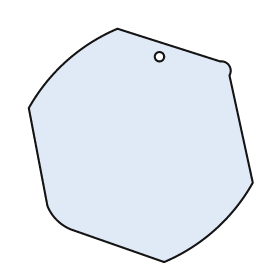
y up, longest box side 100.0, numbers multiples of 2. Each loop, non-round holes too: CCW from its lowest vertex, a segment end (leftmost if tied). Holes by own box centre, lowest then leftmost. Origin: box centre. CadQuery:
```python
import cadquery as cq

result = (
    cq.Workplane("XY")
    .moveTo(10.0, -50.0)
    .threePointArc((32.0, -36.0), (48.0, -16.0))
    .lineTo(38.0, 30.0)
    .threePointArc((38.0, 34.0), (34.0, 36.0))
    .lineTo(-10.0, 50.0)
    .threePointArc((-32.0, 36.0), (-48.0, 16.0))
    .lineTo(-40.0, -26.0)
    .threePointArc((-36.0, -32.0), (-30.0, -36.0))
    .close()
    .moveTo(8.0, 38.0)
    .circle(2.0)
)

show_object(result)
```